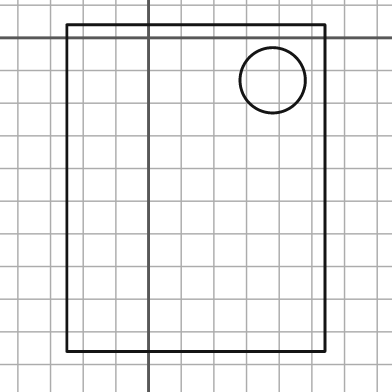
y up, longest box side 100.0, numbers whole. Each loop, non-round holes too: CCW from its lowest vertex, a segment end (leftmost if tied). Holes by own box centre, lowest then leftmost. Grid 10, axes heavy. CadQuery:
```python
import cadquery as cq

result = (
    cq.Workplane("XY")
    .moveTo(-25.0, -96.0)
    .lineTo(54.0, -96.0)
    .lineTo(54.0, 4.0)
    .lineTo(-25.0, 4.0)
    .close()
    .moveTo(38.0, -13.0)
    .circle(10.0)
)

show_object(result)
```